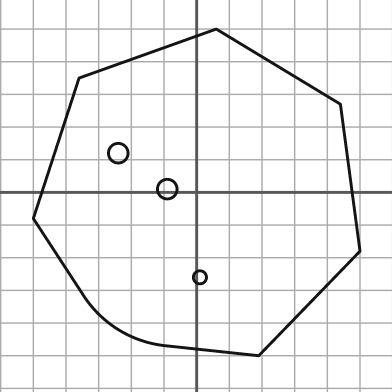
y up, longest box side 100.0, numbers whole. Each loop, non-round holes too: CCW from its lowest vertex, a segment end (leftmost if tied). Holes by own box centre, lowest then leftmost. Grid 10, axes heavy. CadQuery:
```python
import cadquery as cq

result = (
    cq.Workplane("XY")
    .moveTo(19.0, -50.0)
    .lineTo(50.0, -18.0)
    .lineTo(44.0, 27.0)
    .lineTo(6.0, 50.0)
    .lineTo(-36.0, 35.0)
    .lineTo(-50.0, -8.0)
    .lineTo(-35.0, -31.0)
    .threePointArc((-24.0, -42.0), (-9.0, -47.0))
    .close()
    .moveTo(1.0, -26.0)
    .circle(2.0)
    .moveTo(-9.0, 1.0)
    .circle(3.0)
    .moveTo(-24.0, 12.0)
    .circle(3.0)
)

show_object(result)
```